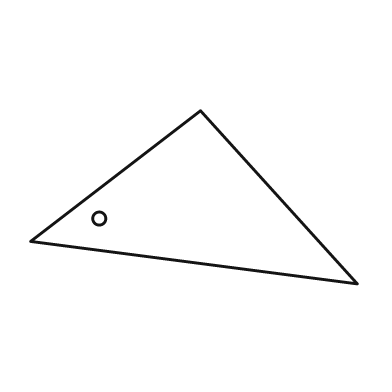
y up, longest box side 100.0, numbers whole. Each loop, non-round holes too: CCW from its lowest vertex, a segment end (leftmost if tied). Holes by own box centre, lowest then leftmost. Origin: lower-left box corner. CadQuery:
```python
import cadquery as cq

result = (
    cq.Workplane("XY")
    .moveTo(100.0, 0.0)
    .lineTo(52.0, 53.0)
    .lineTo(0.0, 13.0)
    .close()
    .moveTo(21.0, 20.0)
    .circle(2.0)
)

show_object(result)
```